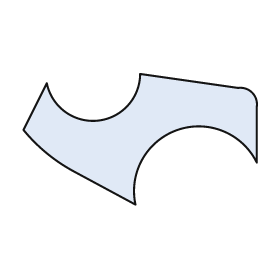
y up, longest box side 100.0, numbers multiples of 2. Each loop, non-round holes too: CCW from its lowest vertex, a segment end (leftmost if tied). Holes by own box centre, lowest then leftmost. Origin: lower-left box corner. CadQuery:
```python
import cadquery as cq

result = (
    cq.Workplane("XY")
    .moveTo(48.0, 0.0)
    .threePointArc((66.0, 32.0), (100.0, 18.0))
    .lineTo(100.0, 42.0)
    .threePointArc((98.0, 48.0), (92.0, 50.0))
    .lineTo(50.0, 56.0)
    .threePointArc((32.0, 36.0), (10.0, 52.0))
    .lineTo(0.0, 32.0)
    .threePointArc((10.0, 22.0), (22.0, 14.0))
    .close()
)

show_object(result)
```